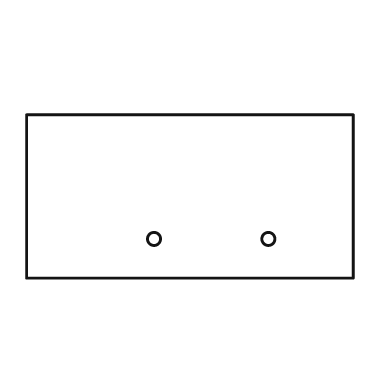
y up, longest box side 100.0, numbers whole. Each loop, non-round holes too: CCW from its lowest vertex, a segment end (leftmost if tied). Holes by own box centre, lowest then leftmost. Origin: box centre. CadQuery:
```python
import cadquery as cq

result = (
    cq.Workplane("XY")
    .moveTo(-50.0, -25.0)
    .lineTo(50.0, -25.0)
    .lineTo(50.0, 25.0)
    .lineTo(-50.0, 25.0)
    .close()
    .moveTo(-11.0, -13.0)
    .circle(2.0)
    .moveTo(24.0, -13.0)
    .circle(2.0)
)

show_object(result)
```